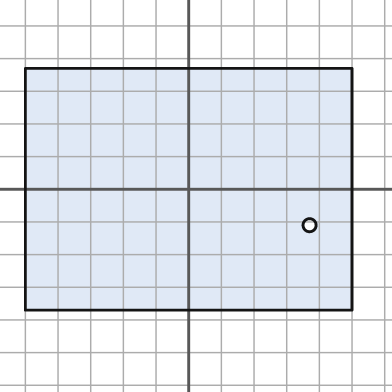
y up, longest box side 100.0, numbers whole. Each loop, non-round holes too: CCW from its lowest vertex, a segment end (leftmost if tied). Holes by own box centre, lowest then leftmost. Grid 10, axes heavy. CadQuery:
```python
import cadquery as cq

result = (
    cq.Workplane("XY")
    .moveTo(-50.0, -37.0)
    .lineTo(50.0, -37.0)
    .lineTo(50.0, 37.0)
    .lineTo(-50.0, 37.0)
    .close()
    .moveTo(37.0, -11.0)
    .circle(2.0)
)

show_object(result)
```